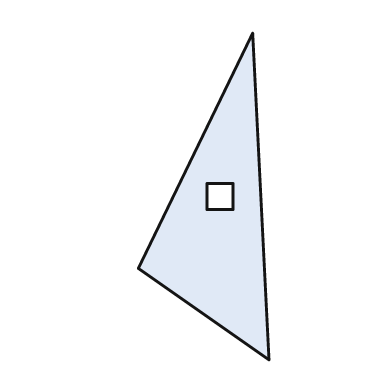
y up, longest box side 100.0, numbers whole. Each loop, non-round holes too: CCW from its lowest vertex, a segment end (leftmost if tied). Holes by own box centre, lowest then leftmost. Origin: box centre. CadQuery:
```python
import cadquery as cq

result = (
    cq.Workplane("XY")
    .moveTo(20.0, -50.0)
    .lineTo(15.0, 50.0)
    .lineTo(-20.0, -22.0)
    .close()
    .moveTo(1.0, -4.0)
    .lineTo(9.0, -4.0)
    .lineTo(9.0, 4.0)
    .lineTo(1.0, 4.0)
    .close()
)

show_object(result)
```